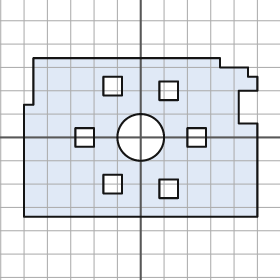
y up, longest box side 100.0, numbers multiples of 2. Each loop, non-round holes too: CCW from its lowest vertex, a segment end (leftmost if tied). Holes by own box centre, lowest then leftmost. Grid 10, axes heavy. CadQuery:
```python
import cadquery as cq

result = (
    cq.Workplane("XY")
    .moveTo(-50.0, -34.0)
    .lineTo(50.0, -34.0)
    .lineTo(50.0, 6.0)
    .lineTo(42.0, 6.0)
    .lineTo(42.0, 20.0)
    .lineTo(50.0, 20.0)
    .lineTo(50.0, 26.0)
    .lineTo(46.0, 26.0)
    .lineTo(46.0, 30.0)
    .lineTo(34.0, 30.0)
    .lineTo(34.0, 34.0)
    .lineTo(-46.0, 34.0)
    .lineTo(-46.0, 14.0)
    .lineTo(-50.0, 14.0)
    .close()
    .moveTo(8.0, -26.0)
    .lineTo(16.0, -26.0)
    .lineTo(16.0, -18.0)
    .lineTo(8.0, -18.0)
    .close()
    .moveTo(-16.0, -24.0)
    .lineTo(-8.0, -24.0)
    .lineTo(-8.0, -16.0)
    .lineTo(-16.0, -16.0)
    .close()
    .moveTo(-28.0, -4.0)
    .lineTo(-20.0, -4.0)
    .lineTo(-20.0, 4.0)
    .lineTo(-28.0, 4.0)
    .close()
    .moveTo(0.0, 0.0)
    .circle(10.0)
    .moveTo(20.0, -4.0)
    .lineTo(28.0, -4.0)
    .lineTo(28.0, 4.0)
    .lineTo(20.0, 4.0)
    .close()
    .moveTo(8.0, 16.0)
    .lineTo(16.0, 16.0)
    .lineTo(16.0, 24.0)
    .lineTo(8.0, 24.0)
    .close()
    .moveTo(-16.0, 18.0)
    .lineTo(-8.0, 18.0)
    .lineTo(-8.0, 26.0)
    .lineTo(-16.0, 26.0)
    .close()
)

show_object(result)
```